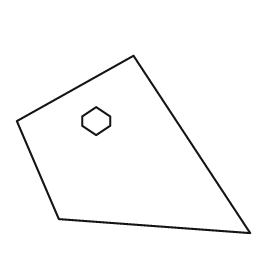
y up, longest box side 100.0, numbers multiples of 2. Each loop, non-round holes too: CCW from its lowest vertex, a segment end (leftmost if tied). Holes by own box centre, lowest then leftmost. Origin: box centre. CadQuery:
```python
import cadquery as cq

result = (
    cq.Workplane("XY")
    .moveTo(50.0, -38.0)
    .lineTo(0.0, 38.0)
    .lineTo(-50.0, 10.0)
    .lineTo(-32.0, -32.0)
    .close()
    .moveTo(-16.0, 4.0)
    .lineTo(-10.0, 8.0)
    .lineTo(-10.0, 12.0)
    .lineTo(-16.0, 16.0)
    .lineTo(-22.0, 12.0)
    .lineTo(-22.0, 8.0)
    .close()
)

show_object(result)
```